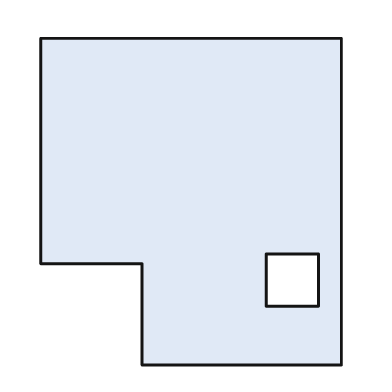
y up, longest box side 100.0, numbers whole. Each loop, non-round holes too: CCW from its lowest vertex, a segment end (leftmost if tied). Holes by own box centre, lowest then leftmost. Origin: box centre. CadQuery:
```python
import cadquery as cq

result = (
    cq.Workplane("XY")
    .moveTo(-15.0, -50.0)
    .lineTo(46.0, -50.0)
    .lineTo(46.0, 50.0)
    .lineTo(-46.0, 50.0)
    .lineTo(-46.0, -19.0)
    .lineTo(-15.0, -19.0)
    .close()
    .moveTo(23.0, -32.0)
    .lineTo(39.0, -32.0)
    .lineTo(39.0, -16.0)
    .lineTo(23.0, -16.0)
    .close()
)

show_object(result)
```